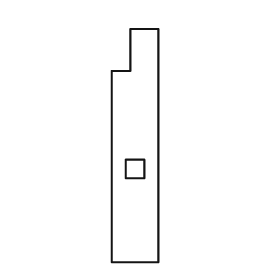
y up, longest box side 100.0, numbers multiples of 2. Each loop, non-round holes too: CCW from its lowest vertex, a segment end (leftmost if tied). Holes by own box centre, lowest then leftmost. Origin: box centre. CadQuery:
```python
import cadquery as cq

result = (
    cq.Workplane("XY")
    .moveTo(-10.0, -50.0)
    .lineTo(10.0, -50.0)
    .lineTo(10.0, 50.0)
    .lineTo(-2.0, 50.0)
    .lineTo(-2.0, 32.0)
    .lineTo(-10.0, 32.0)
    .close()
    .moveTo(-4.0, -14.0)
    .lineTo(4.0, -14.0)
    .lineTo(4.0, -6.0)
    .lineTo(-4.0, -6.0)
    .close()
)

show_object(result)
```